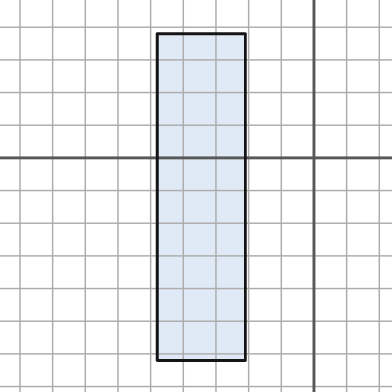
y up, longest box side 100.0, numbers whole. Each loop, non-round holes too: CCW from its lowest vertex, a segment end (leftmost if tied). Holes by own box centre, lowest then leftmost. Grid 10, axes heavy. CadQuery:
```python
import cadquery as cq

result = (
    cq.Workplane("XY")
    .moveTo(-48.0, -62.0)
    .lineTo(-21.0, -62.0)
    .lineTo(-21.0, 38.0)
    .lineTo(-48.0, 38.0)
    .close()
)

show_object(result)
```